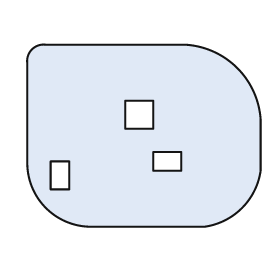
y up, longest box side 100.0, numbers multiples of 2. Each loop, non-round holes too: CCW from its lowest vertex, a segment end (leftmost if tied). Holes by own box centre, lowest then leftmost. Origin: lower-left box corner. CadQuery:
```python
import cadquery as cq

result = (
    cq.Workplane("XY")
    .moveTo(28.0, 0.0)
    .lineTo(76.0, 0.0)
    .threePointArc((92.0, 8.0), (100.0, 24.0))
    .lineTo(100.0, 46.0)
    .threePointArc((90.0, 68.0), (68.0, 78.0))
    .lineTo(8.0, 78.0)
    .threePointArc((2.0, 76.0), (0.0, 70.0))
    .lineTo(0.0, 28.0)
    .threePointArc((8.0, 8.0), (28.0, 0.0))
    .close()
    .moveTo(10.0, 16.0)
    .lineTo(18.0, 16.0)
    .lineTo(18.0, 28.0)
    .lineTo(10.0, 28.0)
    .close()
    .moveTo(54.0, 24.0)
    .lineTo(66.0, 24.0)
    .lineTo(66.0, 32.0)
    .lineTo(54.0, 32.0)
    .close()
    .moveTo(42.0, 42.0)
    .lineTo(54.0, 42.0)
    .lineTo(54.0, 54.0)
    .lineTo(42.0, 54.0)
    .close()
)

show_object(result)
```